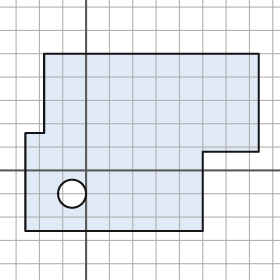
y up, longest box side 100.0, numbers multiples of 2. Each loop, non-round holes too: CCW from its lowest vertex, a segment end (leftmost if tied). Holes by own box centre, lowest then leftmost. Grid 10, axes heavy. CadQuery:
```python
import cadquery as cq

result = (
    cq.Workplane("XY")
    .moveTo(-26.0, -26.0)
    .lineTo(50.0, -26.0)
    .lineTo(50.0, 8.0)
    .lineTo(74.0, 8.0)
    .lineTo(74.0, 50.0)
    .lineTo(-18.0, 50.0)
    .lineTo(-18.0, 16.0)
    .lineTo(-26.0, 16.0)
    .close()
    .moveTo(-6.0, -10.0)
    .circle(6.0)
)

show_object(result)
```